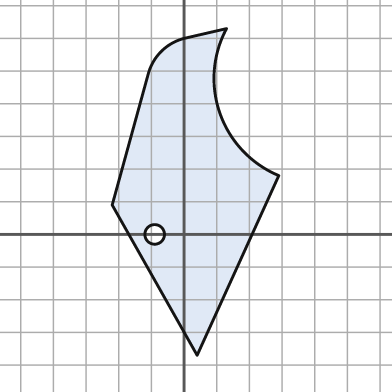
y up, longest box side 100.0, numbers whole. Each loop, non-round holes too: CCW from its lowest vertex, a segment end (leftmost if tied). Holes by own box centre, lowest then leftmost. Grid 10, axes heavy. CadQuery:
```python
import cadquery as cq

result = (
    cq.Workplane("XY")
    .moveTo(4.0, -37.0)
    .lineTo(29.0, 18.0)
    .threePointArc((11.0, 37.0), (13.0, 63.0))
    .lineTo(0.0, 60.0)
    .threePointArc((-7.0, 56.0), (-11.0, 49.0))
    .lineTo(-22.0, 9.0)
    .close()
    .moveTo(-9.0, 0.0)
    .circle(3.0)
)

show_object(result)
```